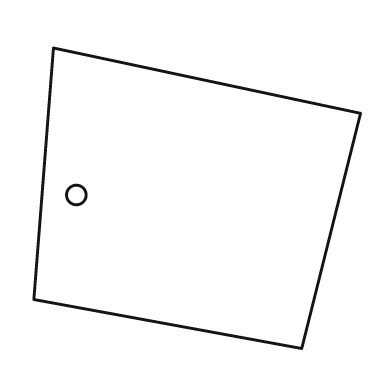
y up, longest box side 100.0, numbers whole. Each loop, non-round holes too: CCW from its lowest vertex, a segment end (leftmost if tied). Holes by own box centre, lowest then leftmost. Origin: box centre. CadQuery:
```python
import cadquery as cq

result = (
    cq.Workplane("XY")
    .moveTo(32.0, -46.0)
    .lineTo(50.0, 26.0)
    .lineTo(-44.0, 46.0)
    .lineTo(-50.0, -31.0)
    .close()
    .moveTo(-37.0, 1.0)
    .circle(3.0)
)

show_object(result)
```